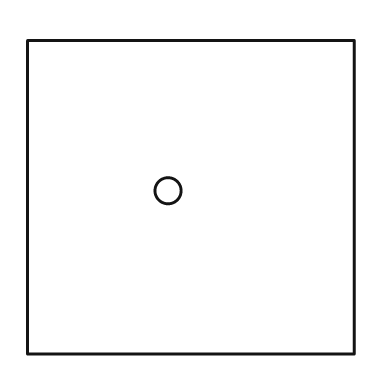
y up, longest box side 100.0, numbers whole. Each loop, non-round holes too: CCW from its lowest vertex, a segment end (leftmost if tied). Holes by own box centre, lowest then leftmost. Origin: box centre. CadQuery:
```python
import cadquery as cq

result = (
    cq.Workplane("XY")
    .moveTo(-50.0, -48.0)
    .lineTo(50.0, -48.0)
    .lineTo(50.0, 48.0)
    .lineTo(-50.0, 48.0)
    .close()
    .moveTo(-7.0, 2.0)
    .circle(4.0)
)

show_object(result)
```